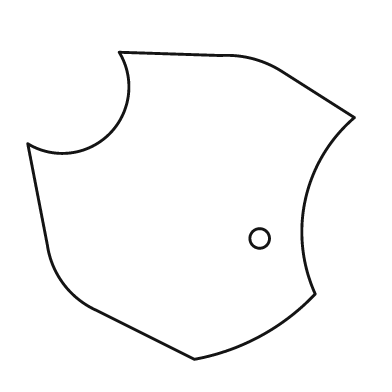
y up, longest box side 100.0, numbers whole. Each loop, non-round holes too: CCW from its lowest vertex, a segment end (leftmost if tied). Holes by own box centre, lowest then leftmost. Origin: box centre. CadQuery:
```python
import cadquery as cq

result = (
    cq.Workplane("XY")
    .moveTo(1.0, -47.0)
    .threePointArc((21.0, -40.0), (38.0, -27.0))
    .threePointArc((35.0, 2.0), (50.0, 27.0))
    .lineTo(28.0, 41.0)
    .threePointArc((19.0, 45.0), (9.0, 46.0))
    .lineTo(-22.0, 47.0)
    .threePointArc((-25.0, 22.0), (-50.0, 19.0))
    .lineTo(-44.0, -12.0)
    .threePointArc((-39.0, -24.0), (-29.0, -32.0))
    .close()
    .moveTo(21.0, -10.0)
    .circle(3.0)
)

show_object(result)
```